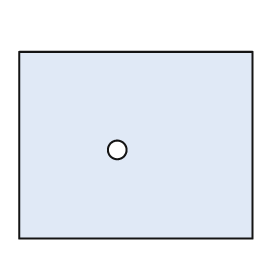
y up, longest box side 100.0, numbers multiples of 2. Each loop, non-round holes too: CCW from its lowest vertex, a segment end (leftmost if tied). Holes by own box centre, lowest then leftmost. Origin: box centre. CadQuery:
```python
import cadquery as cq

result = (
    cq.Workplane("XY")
    .moveTo(-50.0, -40.0)
    .lineTo(50.0, -40.0)
    .lineTo(50.0, 40.0)
    .lineTo(-50.0, 40.0)
    .close()
    .moveTo(-8.0, -2.0)
    .circle(4.0)
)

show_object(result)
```